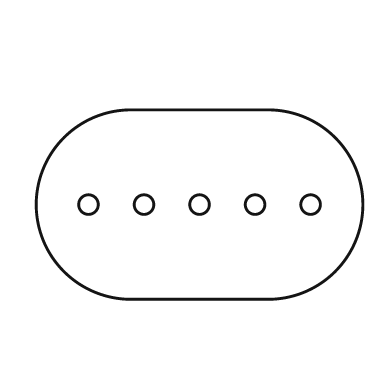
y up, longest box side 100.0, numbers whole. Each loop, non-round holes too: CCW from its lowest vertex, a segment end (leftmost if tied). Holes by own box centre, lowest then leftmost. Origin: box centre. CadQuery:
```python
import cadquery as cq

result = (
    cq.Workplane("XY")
    .moveTo(-21.0, -29.0)
    .lineTo(21.0, -29.0)
    .threePointArc((50.0, 0.0), (21.0, 29.0))
    .lineTo(-21.0, 29.0)
    .threePointArc((-50.0, 0.0), (-21.0, -29.0))
    .close()
    .moveTo(-34.0, 0.0)
    .circle(3.0)
    .moveTo(-17.0, 0.0)
    .circle(3.0)
    .moveTo(0.0, 0.0)
    .circle(3.0)
    .moveTo(17.0, 0.0)
    .circle(3.0)
    .moveTo(34.0, 0.0)
    .circle(3.0)
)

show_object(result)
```